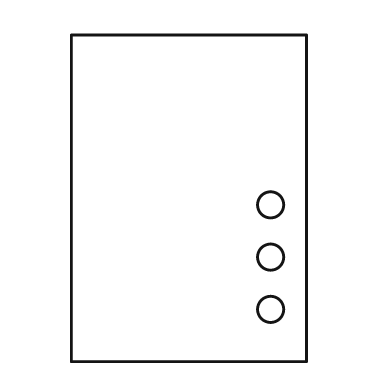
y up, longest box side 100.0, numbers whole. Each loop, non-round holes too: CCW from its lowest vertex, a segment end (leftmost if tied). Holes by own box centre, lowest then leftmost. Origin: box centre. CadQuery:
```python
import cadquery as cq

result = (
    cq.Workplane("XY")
    .moveTo(-36.0, -50.0)
    .lineTo(36.0, -50.0)
    .lineTo(36.0, 50.0)
    .lineTo(-36.0, 50.0)
    .close()
    .moveTo(25.0, -34.0)
    .circle(4.0)
    .moveTo(25.0, -18.0)
    .circle(4.0)
    .moveTo(25.0, -2.0)
    .circle(4.0)
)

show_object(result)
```